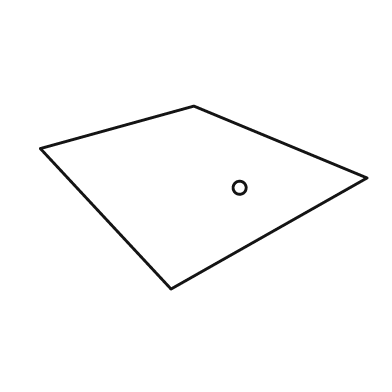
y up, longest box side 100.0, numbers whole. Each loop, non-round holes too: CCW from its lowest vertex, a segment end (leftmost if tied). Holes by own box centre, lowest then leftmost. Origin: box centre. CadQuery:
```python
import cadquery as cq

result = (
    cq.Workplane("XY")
    .moveTo(-10.0, -28.0)
    .lineTo(50.0, 6.0)
    .lineTo(-3.0, 28.0)
    .lineTo(-50.0, 15.0)
    .close()
    .moveTo(11.0, 3.0)
    .circle(2.0)
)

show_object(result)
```